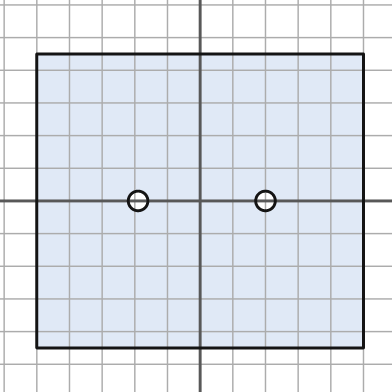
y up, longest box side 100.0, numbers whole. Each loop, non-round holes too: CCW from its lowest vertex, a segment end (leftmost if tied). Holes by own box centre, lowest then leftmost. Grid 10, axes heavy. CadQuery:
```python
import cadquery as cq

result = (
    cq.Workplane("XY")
    .moveTo(-50.0, -45.0)
    .lineTo(50.0, -45.0)
    .lineTo(50.0, 45.0)
    .lineTo(-50.0, 45.0)
    .close()
    .moveTo(-19.0, 0.0)
    .circle(3.0)
    .moveTo(20.0, 0.0)
    .circle(3.0)
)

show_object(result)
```